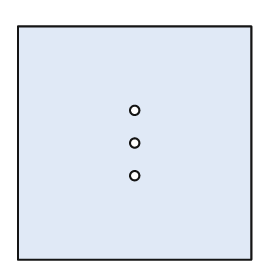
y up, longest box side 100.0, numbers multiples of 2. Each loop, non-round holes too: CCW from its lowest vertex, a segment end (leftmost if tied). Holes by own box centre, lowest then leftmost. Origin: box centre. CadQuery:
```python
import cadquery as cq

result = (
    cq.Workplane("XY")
    .moveTo(-50.0, -50.0)
    .lineTo(50.0, -50.0)
    .lineTo(50.0, 50.0)
    .lineTo(-50.0, 50.0)
    .close()
    .moveTo(0.0, -14.0)
    .circle(2.0)
    .moveTo(0.0, 0.0)
    .circle(2.0)
    .moveTo(0.0, 14.0)
    .circle(2.0)
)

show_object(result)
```